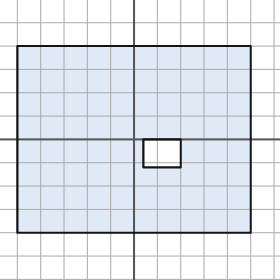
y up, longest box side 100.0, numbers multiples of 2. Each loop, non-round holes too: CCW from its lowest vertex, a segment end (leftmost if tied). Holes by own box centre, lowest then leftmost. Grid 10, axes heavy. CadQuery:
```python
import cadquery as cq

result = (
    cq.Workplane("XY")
    .moveTo(-50.0, -40.0)
    .lineTo(50.0, -40.0)
    .lineTo(50.0, 40.0)
    .lineTo(-50.0, 40.0)
    .close()
    .moveTo(4.0, -12.0)
    .lineTo(20.0, -12.0)
    .lineTo(20.0, 0.0)
    .lineTo(4.0, 0.0)
    .close()
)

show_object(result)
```